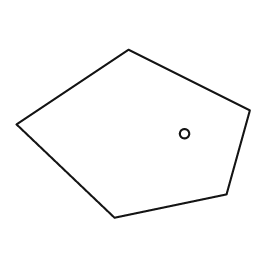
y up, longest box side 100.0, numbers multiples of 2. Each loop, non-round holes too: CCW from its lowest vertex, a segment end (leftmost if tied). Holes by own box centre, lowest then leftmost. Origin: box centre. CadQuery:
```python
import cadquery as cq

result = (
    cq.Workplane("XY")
    .moveTo(-8.0, -36.0)
    .lineTo(40.0, -26.0)
    .lineTo(50.0, 10.0)
    .lineTo(-2.0, 36.0)
    .lineTo(-50.0, 4.0)
    .close()
    .moveTo(22.0, 0.0)
    .circle(2.0)
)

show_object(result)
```